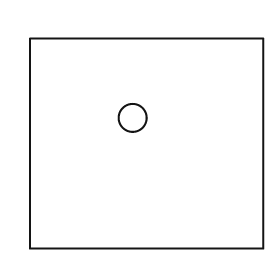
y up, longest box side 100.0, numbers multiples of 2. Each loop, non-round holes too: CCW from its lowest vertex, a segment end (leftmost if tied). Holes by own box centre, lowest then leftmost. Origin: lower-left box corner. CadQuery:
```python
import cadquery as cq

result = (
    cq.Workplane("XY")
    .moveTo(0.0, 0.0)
    .lineTo(100.0, 0.0)
    .lineTo(100.0, 90.0)
    .lineTo(0.0, 90.0)
    .close()
    .moveTo(44.0, 56.0)
    .circle(6.0)
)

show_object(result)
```